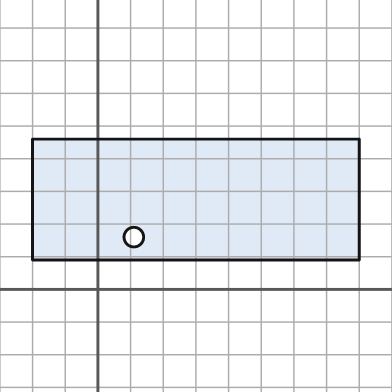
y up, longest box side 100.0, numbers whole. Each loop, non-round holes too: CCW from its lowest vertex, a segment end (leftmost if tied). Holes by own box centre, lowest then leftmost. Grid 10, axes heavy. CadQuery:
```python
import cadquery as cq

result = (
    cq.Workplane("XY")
    .moveTo(-20.0, 9.0)
    .lineTo(80.0, 9.0)
    .lineTo(80.0, 46.0)
    .lineTo(-20.0, 46.0)
    .close()
    .moveTo(11.0, 16.0)
    .circle(3.0)
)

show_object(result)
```